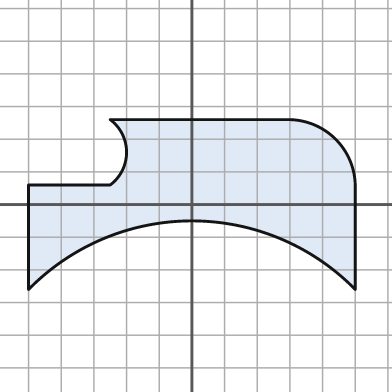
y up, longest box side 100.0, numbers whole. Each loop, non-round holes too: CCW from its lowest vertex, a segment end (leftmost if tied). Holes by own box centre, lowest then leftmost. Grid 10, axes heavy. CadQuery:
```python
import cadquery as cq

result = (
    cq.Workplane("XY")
    .moveTo(-50.0, -26.0)
    .threePointArc((0.0, -5.0), (50.0, -26.0))
    .lineTo(50.0, 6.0)
    .threePointArc((44.0, 20.0), (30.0, 26.0))
    .lineTo(-25.0, 26.0)
    .threePointArc((-20.0, 16.0), (-25.0, 6.0))
    .lineTo(-50.0, 6.0)
    .close()
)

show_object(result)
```